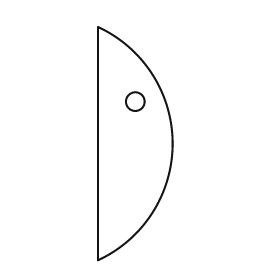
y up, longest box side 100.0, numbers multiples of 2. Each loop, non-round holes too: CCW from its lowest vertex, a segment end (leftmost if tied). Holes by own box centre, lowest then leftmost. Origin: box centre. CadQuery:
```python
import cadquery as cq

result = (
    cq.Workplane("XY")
    .moveTo(-16.0, -50.0)
    .threePointArc((16.0, 0.0), (-16.0, 50.0))
    .close()
    .moveTo(0.0, 18.0)
    .circle(4.0)
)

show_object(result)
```